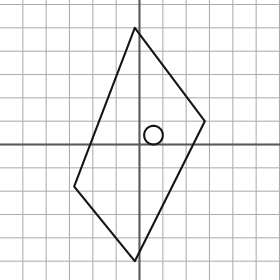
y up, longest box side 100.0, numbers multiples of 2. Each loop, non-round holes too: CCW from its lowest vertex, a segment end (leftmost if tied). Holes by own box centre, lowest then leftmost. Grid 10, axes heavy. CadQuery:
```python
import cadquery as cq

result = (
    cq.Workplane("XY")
    .moveTo(-2.0, -50.0)
    .lineTo(28.0, 10.0)
    .lineTo(-2.0, 50.0)
    .lineTo(-28.0, -18.0)
    .close()
    .moveTo(6.0, 4.0)
    .circle(4.0)
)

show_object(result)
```